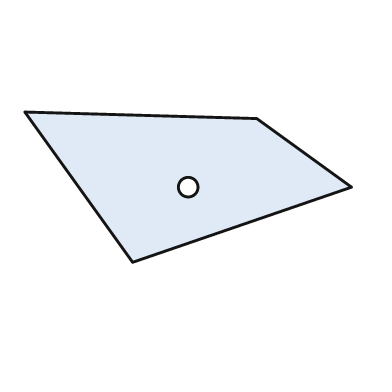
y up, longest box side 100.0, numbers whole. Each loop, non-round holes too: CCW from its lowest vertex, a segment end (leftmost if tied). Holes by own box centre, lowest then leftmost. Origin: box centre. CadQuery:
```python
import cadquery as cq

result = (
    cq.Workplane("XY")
    .moveTo(-17.0, -23.0)
    .lineTo(50.0, 0.0)
    .lineTo(21.0, 21.0)
    .lineTo(-50.0, 23.0)
    .close()
    .moveTo(0.0, 0.0)
    .circle(3.0)
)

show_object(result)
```